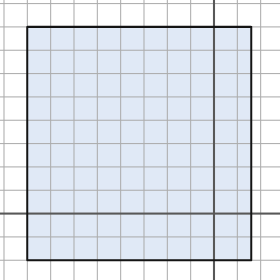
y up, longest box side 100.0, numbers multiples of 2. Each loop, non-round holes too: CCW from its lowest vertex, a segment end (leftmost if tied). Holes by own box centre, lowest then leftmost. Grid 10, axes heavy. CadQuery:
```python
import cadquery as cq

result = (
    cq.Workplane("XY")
    .moveTo(-80.0, -20.0)
    .lineTo(16.0, -20.0)
    .lineTo(16.0, 80.0)
    .lineTo(-80.0, 80.0)
    .close()
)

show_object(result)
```